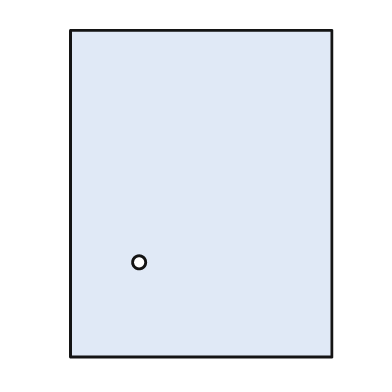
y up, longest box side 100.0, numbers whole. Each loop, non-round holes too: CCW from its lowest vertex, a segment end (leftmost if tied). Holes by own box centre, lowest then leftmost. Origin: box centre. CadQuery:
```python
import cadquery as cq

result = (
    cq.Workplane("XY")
    .moveTo(-40.0, -50.0)
    .lineTo(40.0, -50.0)
    .lineTo(40.0, 50.0)
    .lineTo(-40.0, 50.0)
    .close()
    .moveTo(-19.0, -21.0)
    .circle(2.0)
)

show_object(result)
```